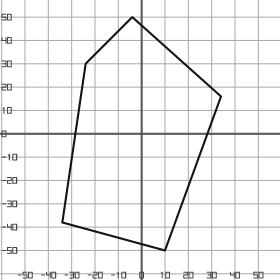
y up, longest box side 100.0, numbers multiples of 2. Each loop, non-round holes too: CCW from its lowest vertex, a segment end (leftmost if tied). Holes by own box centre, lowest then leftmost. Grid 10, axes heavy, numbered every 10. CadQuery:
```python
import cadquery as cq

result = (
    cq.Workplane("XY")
    .moveTo(10.0, -50.0)
    .lineTo(34.0, 16.0)
    .lineTo(-4.0, 50.0)
    .lineTo(-24.0, 30.0)
    .lineTo(-34.0, -38.0)
    .close()
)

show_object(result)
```